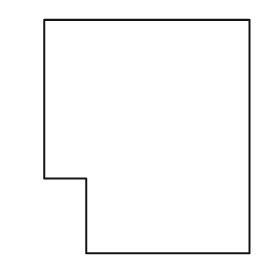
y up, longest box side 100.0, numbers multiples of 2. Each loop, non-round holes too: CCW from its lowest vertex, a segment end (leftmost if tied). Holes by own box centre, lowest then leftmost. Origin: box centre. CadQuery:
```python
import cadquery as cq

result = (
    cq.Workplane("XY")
    .moveTo(-26.0, -50.0)
    .lineTo(44.0, -50.0)
    .lineTo(44.0, 50.0)
    .lineTo(-44.0, 50.0)
    .lineTo(-44.0, -18.0)
    .lineTo(-26.0, -18.0)
    .close()
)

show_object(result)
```